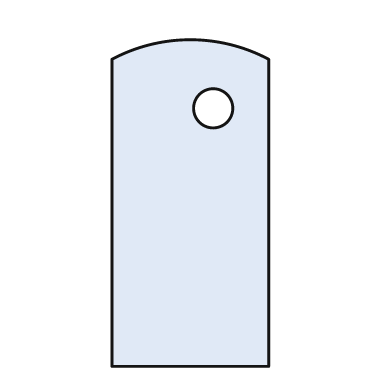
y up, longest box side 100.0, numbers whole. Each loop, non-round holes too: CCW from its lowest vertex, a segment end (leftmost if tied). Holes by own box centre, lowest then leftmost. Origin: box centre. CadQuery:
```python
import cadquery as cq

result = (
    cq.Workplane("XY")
    .moveTo(-24.0, -50.0)
    .lineTo(24.0, -50.0)
    .lineTo(24.0, 44.0)
    .threePointArc((0.0, 50.0), (-24.0, 44.0))
    .close()
    .moveTo(7.0, 29.0)
    .circle(6.0)
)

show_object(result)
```